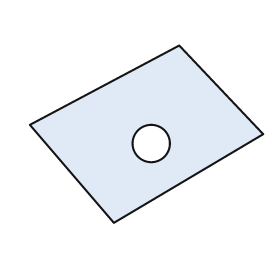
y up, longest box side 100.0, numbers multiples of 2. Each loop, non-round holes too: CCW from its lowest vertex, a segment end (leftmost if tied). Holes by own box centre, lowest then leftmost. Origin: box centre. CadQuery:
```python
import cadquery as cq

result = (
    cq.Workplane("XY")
    .moveTo(-14.0, -38.0)
    .lineTo(50.0, 0.0)
    .lineTo(14.0, 38.0)
    .lineTo(-50.0, 4.0)
    .close()
    .moveTo(2.0, -4.0)
    .circle(8.0)
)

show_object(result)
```